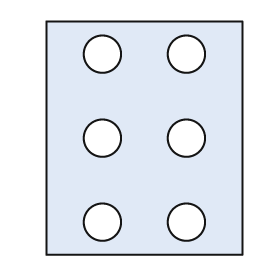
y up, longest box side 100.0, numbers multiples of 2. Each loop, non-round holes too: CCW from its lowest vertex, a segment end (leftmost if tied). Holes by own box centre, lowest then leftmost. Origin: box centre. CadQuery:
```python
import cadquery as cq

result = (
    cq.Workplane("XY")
    .moveTo(-42.0, -50.0)
    .lineTo(42.0, -50.0)
    .lineTo(42.0, 50.0)
    .lineTo(-42.0, 50.0)
    .close()
    .moveTo(-18.0, -36.0)
    .circle(8.0)
    .moveTo(18.0, -36.0)
    .circle(8.0)
    .moveTo(-18.0, 0.0)
    .circle(8.0)
    .moveTo(18.0, 0.0)
    .circle(8.0)
    .moveTo(-18.0, 36.0)
    .circle(8.0)
    .moveTo(18.0, 36.0)
    .circle(8.0)
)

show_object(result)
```